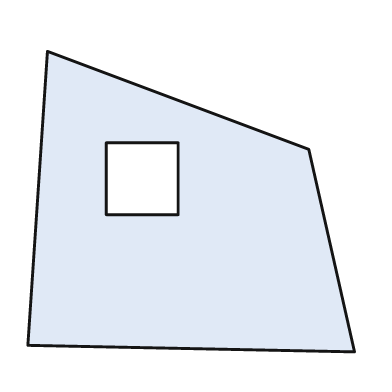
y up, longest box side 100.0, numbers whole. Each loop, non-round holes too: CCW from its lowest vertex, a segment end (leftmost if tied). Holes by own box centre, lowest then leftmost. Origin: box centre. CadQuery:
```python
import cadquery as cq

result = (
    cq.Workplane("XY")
    .moveTo(50.0, -46.0)
    .lineTo(36.0, 16.0)
    .lineTo(-44.0, 46.0)
    .lineTo(-50.0, -44.0)
    .close()
    .moveTo(-26.0, -4.0)
    .lineTo(-4.0, -4.0)
    .lineTo(-4.0, 18.0)
    .lineTo(-26.0, 18.0)
    .close()
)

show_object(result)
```